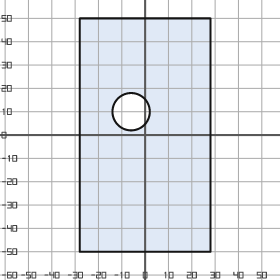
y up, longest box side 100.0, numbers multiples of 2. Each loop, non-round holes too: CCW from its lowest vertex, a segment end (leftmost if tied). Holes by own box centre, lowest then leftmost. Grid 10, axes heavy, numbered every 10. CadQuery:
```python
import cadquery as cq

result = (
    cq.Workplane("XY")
    .moveTo(-28.0, -50.0)
    .lineTo(28.0, -50.0)
    .lineTo(28.0, 50.0)
    .lineTo(-28.0, 50.0)
    .close()
    .moveTo(-6.0, 10.0)
    .circle(8.0)
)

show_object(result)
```